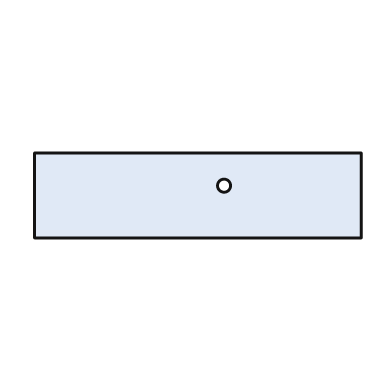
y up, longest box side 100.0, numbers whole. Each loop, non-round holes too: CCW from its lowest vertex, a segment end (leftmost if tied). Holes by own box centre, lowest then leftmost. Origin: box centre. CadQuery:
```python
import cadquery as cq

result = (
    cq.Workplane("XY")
    .moveTo(-50.0, -13.0)
    .lineTo(50.0, -13.0)
    .lineTo(50.0, 13.0)
    .lineTo(-50.0, 13.0)
    .close()
    .moveTo(8.0, 3.0)
    .circle(2.0)
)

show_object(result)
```